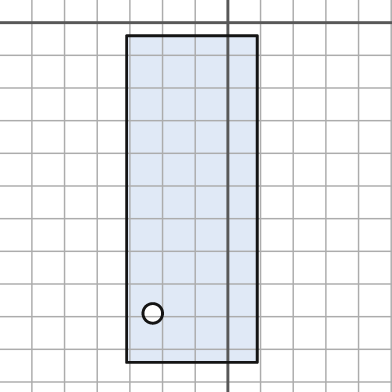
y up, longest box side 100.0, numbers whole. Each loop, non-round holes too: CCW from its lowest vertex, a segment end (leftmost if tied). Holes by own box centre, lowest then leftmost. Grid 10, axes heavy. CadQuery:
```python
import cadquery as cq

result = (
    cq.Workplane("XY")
    .moveTo(-31.0, -104.0)
    .lineTo(9.0, -104.0)
    .lineTo(9.0, -4.0)
    .lineTo(-31.0, -4.0)
    .close()
    .moveTo(-23.0, -89.0)
    .circle(3.0)
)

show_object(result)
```